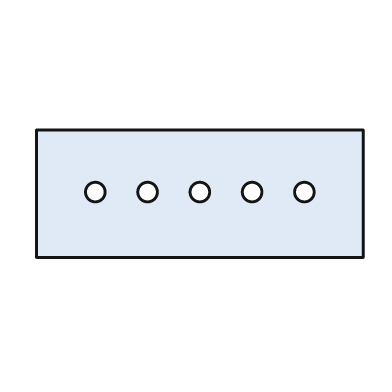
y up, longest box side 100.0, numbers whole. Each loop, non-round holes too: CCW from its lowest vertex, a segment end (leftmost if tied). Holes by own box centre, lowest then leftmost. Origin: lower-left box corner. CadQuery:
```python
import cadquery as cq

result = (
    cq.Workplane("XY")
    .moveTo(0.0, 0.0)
    .lineTo(100.0, 0.0)
    .lineTo(100.0, 39.0)
    .lineTo(0.0, 39.0)
    .close()
    .moveTo(18.0, 20.0)
    .circle(3.0)
    .moveTo(34.0, 20.0)
    .circle(3.0)
    .moveTo(50.0, 20.0)
    .circle(3.0)
    .moveTo(66.0, 20.0)
    .circle(3.0)
    .moveTo(82.0, 20.0)
    .circle(3.0)
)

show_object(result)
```